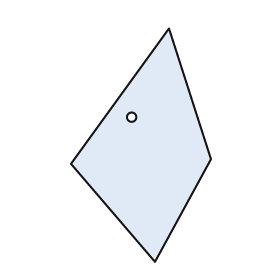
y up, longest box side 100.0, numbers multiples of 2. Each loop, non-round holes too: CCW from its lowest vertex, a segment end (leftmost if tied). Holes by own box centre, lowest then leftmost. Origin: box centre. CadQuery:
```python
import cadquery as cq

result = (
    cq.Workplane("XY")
    .moveTo(6.0, -50.0)
    .lineTo(30.0, -6.0)
    .lineTo(12.0, 50.0)
    .lineTo(-30.0, -8.0)
    .close()
    .moveTo(-4.0, 12.0)
    .circle(2.0)
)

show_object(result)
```